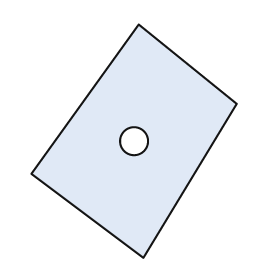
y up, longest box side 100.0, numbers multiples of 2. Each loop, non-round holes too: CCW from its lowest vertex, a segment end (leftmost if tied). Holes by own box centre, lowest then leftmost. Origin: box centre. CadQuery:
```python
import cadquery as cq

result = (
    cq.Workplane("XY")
    .moveTo(4.0, -50.0)
    .lineTo(44.0, 16.0)
    .lineTo(2.0, 50.0)
    .lineTo(-44.0, -14.0)
    .close()
    .moveTo(0.0, 0.0)
    .circle(6.0)
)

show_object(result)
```